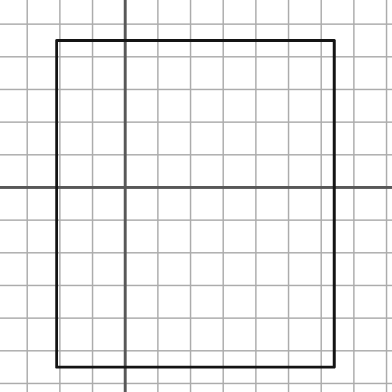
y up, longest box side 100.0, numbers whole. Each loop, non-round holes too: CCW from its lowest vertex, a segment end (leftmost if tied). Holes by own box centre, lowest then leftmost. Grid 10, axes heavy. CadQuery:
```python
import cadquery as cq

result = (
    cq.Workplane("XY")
    .moveTo(-21.0, -55.0)
    .lineTo(64.0, -55.0)
    .lineTo(64.0, 45.0)
    .lineTo(-21.0, 45.0)
    .close()
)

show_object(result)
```